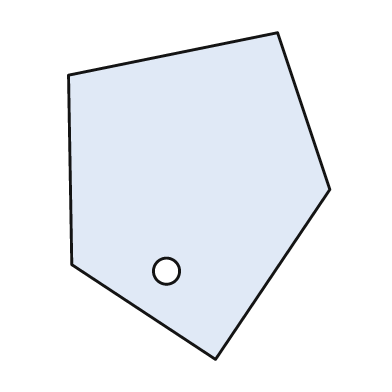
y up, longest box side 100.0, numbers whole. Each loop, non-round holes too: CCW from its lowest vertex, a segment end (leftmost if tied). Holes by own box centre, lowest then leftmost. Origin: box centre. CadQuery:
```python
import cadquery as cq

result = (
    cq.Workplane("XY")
    .moveTo(5.0, -50.0)
    .lineTo(40.0, 2.0)
    .lineTo(24.0, 50.0)
    .lineTo(-40.0, 37.0)
    .lineTo(-39.0, -21.0)
    .close()
    .moveTo(-10.0, -23.0)
    .circle(4.0)
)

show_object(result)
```